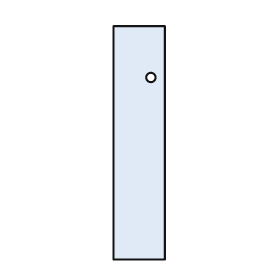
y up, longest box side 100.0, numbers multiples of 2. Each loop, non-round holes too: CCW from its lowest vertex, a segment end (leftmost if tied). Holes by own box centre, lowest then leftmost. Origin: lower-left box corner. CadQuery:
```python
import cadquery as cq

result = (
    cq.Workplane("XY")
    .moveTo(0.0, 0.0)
    .lineTo(22.0, 0.0)
    .lineTo(22.0, 100.0)
    .lineTo(0.0, 100.0)
    .close()
    .moveTo(16.0, 78.0)
    .circle(2.0)
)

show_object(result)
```